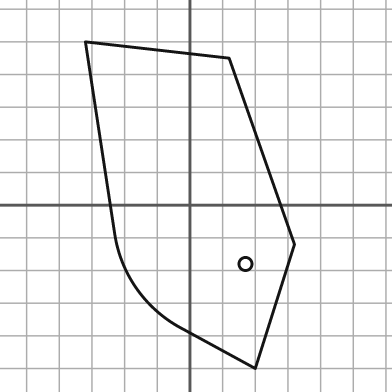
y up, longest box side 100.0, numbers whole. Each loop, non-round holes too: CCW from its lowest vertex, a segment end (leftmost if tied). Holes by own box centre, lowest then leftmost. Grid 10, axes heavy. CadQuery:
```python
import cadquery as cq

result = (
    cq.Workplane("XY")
    .moveTo(20.0, -50.0)
    .lineTo(32.0, -12.0)
    .lineTo(12.0, 45.0)
    .lineTo(-32.0, 50.0)
    .lineTo(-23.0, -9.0)
    .threePointArc((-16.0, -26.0), (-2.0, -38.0))
    .close()
    .moveTo(17.0, -18.0)
    .circle(2.0)
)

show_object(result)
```